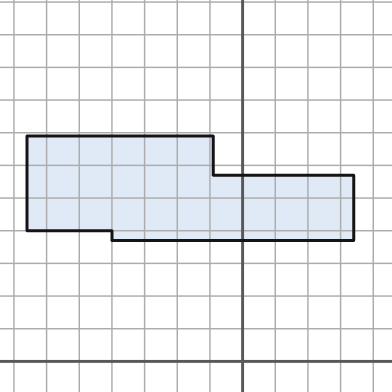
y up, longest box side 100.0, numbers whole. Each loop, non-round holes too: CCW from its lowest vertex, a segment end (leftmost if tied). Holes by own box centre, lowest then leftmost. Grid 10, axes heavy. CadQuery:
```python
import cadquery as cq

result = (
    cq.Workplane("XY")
    .moveTo(-40.0, 37.0)
    .lineTo(34.0, 37.0)
    .lineTo(34.0, 57.0)
    .lineTo(-9.0, 57.0)
    .lineTo(-9.0, 69.0)
    .lineTo(-66.0, 69.0)
    .lineTo(-66.0, 40.0)
    .lineTo(-40.0, 40.0)
    .close()
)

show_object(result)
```